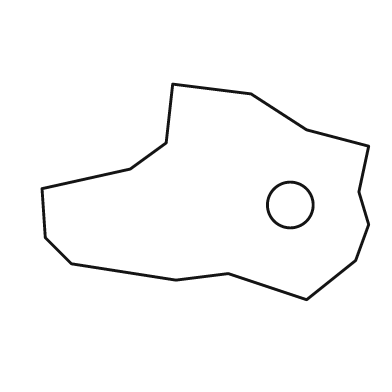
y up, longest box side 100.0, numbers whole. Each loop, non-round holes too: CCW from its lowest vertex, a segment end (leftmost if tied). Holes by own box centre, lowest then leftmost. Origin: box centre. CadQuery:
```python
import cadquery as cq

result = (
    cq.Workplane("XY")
    .moveTo(31.0, -33.0)
    .lineTo(46.0, -21.0)
    .lineTo(50.0, -10.0)
    .lineTo(47.0, 0.0)
    .lineTo(50.0, 14.0)
    .lineTo(31.0, 19.0)
    .lineTo(14.0, 30.0)
    .lineTo(-10.0, 33.0)
    .lineTo(-12.0, 15.0)
    .lineTo(-23.0, 7.0)
    .lineTo(-50.0, 1.0)
    .lineTo(-49.0, -14.0)
    .lineTo(-41.0, -22.0)
    .lineTo(-9.0, -27.0)
    .lineTo(7.0, -25.0)
    .close()
    .moveTo(26.0, -4.0)
    .circle(7.0)
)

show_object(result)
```